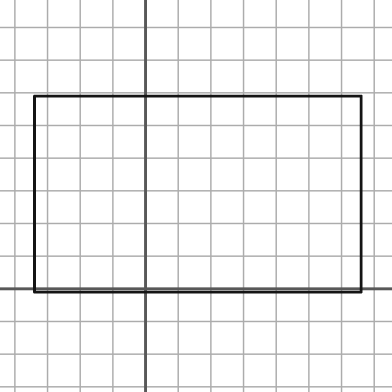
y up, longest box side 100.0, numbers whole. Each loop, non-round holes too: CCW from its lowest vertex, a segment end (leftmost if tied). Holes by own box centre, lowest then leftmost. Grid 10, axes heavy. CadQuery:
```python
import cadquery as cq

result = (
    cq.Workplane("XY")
    .moveTo(-34.0, -1.0)
    .lineTo(66.0, -1.0)
    .lineTo(66.0, 59.0)
    .lineTo(-34.0, 59.0)
    .close()
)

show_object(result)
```